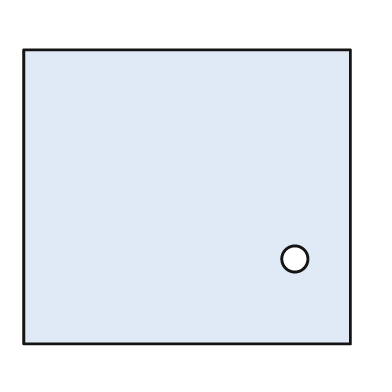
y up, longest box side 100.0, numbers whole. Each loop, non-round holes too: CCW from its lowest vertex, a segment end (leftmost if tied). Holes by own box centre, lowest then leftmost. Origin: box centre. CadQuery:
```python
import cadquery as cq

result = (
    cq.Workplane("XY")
    .moveTo(-50.0, -45.0)
    .lineTo(50.0, -45.0)
    .lineTo(50.0, 45.0)
    .lineTo(-50.0, 45.0)
    .close()
    .moveTo(33.0, -19.0)
    .circle(4.0)
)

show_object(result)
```